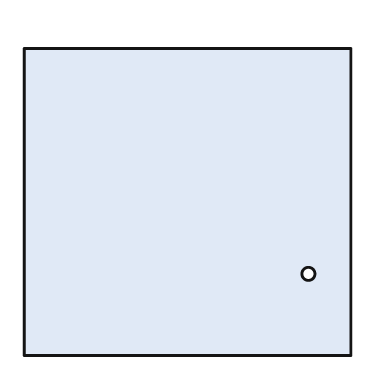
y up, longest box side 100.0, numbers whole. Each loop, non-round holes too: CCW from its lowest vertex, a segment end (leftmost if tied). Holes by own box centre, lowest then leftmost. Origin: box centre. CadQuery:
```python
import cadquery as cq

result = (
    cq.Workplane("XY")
    .moveTo(-50.0, -47.0)
    .lineTo(50.0, -47.0)
    .lineTo(50.0, 47.0)
    .lineTo(-50.0, 47.0)
    .close()
    .moveTo(37.0, -22.0)
    .circle(2.0)
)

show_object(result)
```